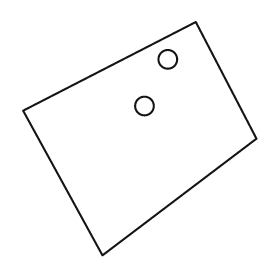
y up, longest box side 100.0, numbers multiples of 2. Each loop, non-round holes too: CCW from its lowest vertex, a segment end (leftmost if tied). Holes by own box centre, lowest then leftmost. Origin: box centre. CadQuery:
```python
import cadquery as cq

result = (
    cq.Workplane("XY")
    .moveTo(-16.0, -50.0)
    .lineTo(50.0, 0.0)
    .lineTo(24.0, 50.0)
    .lineTo(-50.0, 12.0)
    .close()
    .moveTo(2.0, 14.0)
    .circle(4.0)
    .moveTo(12.0, 34.0)
    .circle(4.0)
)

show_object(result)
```